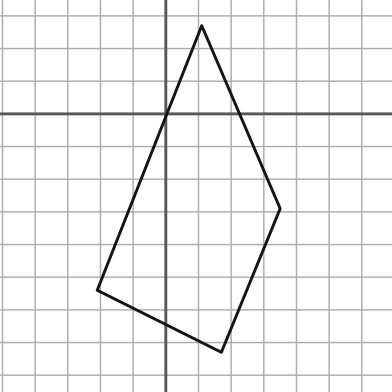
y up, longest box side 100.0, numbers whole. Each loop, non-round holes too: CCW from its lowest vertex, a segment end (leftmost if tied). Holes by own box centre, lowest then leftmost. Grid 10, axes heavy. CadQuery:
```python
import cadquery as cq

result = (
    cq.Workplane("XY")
    .moveTo(17.0, -73.0)
    .lineTo(35.0, -29.0)
    .lineTo(11.0, 27.0)
    .lineTo(-21.0, -54.0)
    .close()
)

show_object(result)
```